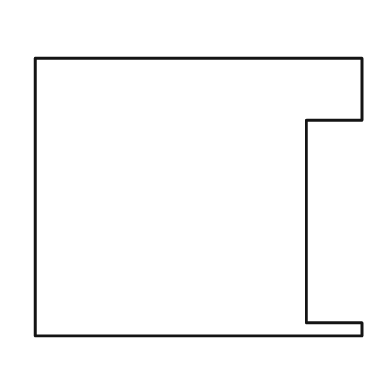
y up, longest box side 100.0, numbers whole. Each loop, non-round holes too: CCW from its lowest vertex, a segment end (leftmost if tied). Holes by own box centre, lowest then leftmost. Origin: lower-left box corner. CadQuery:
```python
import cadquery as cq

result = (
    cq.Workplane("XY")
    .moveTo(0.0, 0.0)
    .lineTo(100.0, 0.0)
    .lineTo(100.0, 4.0)
    .lineTo(83.0, 4.0)
    .lineTo(83.0, 66.0)
    .lineTo(100.0, 66.0)
    .lineTo(100.0, 85.0)
    .lineTo(0.0, 85.0)
    .close()
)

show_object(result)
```